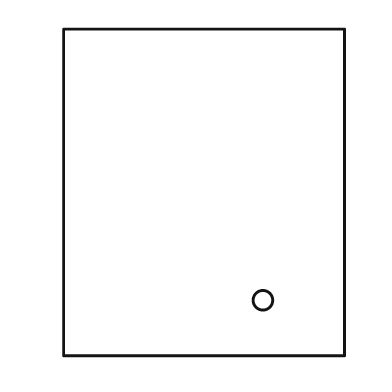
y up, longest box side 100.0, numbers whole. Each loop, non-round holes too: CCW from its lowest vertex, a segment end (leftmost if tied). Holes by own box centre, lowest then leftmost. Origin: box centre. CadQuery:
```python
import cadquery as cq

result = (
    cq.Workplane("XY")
    .moveTo(-43.0, -50.0)
    .lineTo(43.0, -50.0)
    .lineTo(43.0, 50.0)
    .lineTo(-43.0, 50.0)
    .close()
    .moveTo(18.0, -33.0)
    .circle(3.0)
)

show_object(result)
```